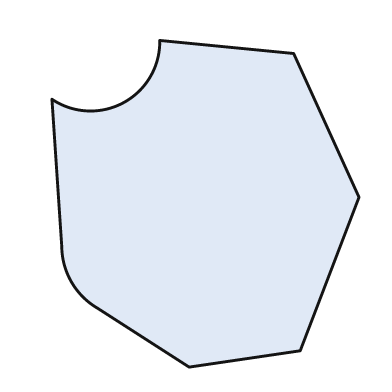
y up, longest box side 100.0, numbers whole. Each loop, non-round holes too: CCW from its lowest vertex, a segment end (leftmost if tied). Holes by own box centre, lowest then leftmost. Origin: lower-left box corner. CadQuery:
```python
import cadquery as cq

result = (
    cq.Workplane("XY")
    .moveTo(42.0, 0.0)
    .lineTo(76.0, 5.0)
    .lineTo(94.0, 52.0)
    .lineTo(74.0, 96.0)
    .lineTo(33.0, 100.0)
    .threePointArc((22.0, 81.0), (0.0, 82.0))
    .lineTo(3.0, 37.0)
    .threePointArc((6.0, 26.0), (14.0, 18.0))
    .close()
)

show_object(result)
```